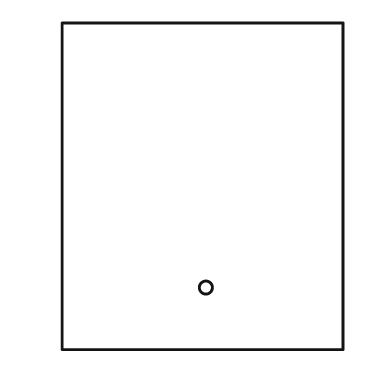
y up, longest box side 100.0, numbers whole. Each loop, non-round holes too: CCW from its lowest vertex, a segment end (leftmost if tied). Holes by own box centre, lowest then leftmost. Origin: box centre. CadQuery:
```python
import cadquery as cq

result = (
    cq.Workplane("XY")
    .moveTo(-43.0, -50.0)
    .lineTo(43.0, -50.0)
    .lineTo(43.0, 50.0)
    .lineTo(-43.0, 50.0)
    .close()
    .moveTo(1.0, -31.0)
    .circle(2.0)
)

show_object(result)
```